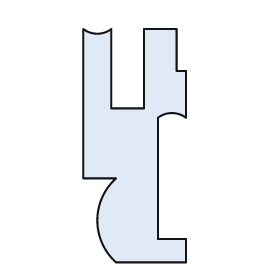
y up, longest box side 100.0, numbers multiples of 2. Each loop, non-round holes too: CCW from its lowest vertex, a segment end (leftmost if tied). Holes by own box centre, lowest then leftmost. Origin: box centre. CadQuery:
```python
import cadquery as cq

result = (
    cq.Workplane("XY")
    .moveTo(-8.0, -50.0)
    .lineTo(22.0, -50.0)
    .lineTo(22.0, -40.0)
    .lineTo(10.0, -40.0)
    .lineTo(10.0, 12.0)
    .threePointArc((16.0, 14.0), (22.0, 12.0))
    .lineTo(22.0, 32.0)
    .lineTo(18.0, 32.0)
    .lineTo(18.0, 50.0)
    .lineTo(4.0, 50.0)
    .lineTo(4.0, 16.0)
    .lineTo(-10.0, 16.0)
    .lineTo(-10.0, 50.0)
    .threePointArc((-16.0, 48.0), (-22.0, 50.0))
    .lineTo(-22.0, -14.0)
    .lineTo(-8.0, -14.0)
    .threePointArc((-16.0, -32.0), (-8.0, -50.0))
    .close()
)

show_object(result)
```